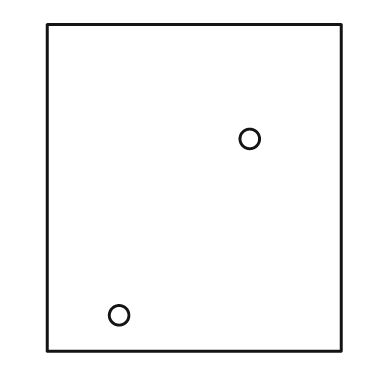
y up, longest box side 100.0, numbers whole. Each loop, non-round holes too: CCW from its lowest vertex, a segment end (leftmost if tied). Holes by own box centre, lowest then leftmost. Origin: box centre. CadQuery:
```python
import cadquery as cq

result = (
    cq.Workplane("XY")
    .moveTo(-45.0, -50.0)
    .lineTo(45.0, -50.0)
    .lineTo(45.0, 50.0)
    .lineTo(-45.0, 50.0)
    .close()
    .moveTo(-23.0, -39.0)
    .circle(3.0)
    .moveTo(17.0, 15.0)
    .circle(3.0)
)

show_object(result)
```